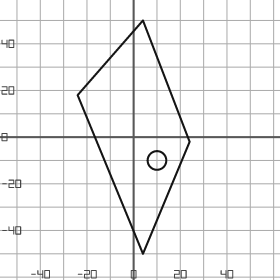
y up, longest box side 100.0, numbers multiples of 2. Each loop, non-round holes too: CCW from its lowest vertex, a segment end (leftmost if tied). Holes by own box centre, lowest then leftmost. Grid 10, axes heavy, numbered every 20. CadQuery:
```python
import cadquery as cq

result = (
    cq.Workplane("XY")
    .moveTo(4.0, -50.0)
    .lineTo(24.0, -2.0)
    .lineTo(4.0, 50.0)
    .lineTo(-24.0, 18.0)
    .close()
    .moveTo(10.0, -10.0)
    .circle(4.0)
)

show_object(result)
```